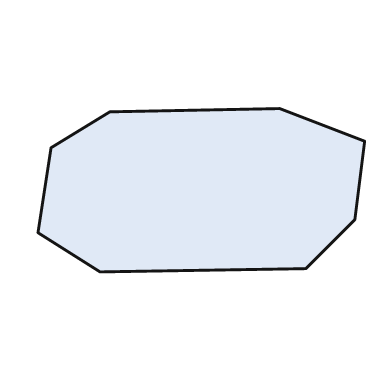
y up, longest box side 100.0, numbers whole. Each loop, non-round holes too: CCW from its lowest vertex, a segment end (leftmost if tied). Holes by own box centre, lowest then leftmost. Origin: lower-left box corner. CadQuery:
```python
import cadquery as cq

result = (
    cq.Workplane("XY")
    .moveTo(19.0, 0.0)
    .lineTo(82.0, 1.0)
    .lineTo(97.0, 16.0)
    .lineTo(100.0, 40.0)
    .lineTo(74.0, 50.0)
    .lineTo(22.0, 49.0)
    .lineTo(4.0, 38.0)
    .lineTo(0.0, 12.0)
    .close()
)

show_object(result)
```